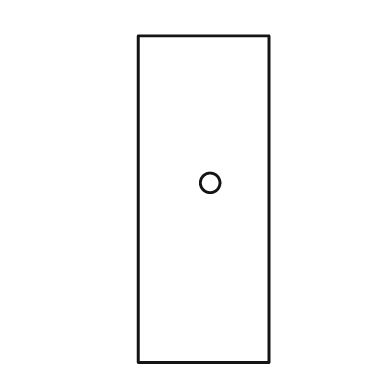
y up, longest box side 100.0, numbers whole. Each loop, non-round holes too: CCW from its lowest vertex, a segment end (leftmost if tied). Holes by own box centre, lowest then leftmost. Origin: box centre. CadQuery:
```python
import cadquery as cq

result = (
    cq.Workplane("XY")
    .moveTo(-20.0, -50.0)
    .lineTo(20.0, -50.0)
    .lineTo(20.0, 50.0)
    .lineTo(-20.0, 50.0)
    .close()
    .moveTo(2.0, 5.0)
    .circle(3.0)
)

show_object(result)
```